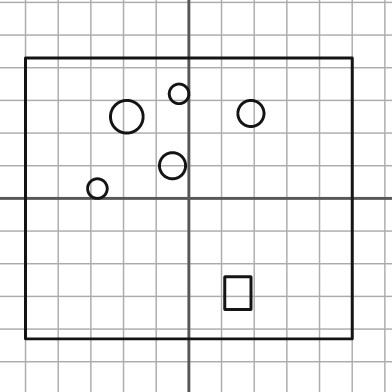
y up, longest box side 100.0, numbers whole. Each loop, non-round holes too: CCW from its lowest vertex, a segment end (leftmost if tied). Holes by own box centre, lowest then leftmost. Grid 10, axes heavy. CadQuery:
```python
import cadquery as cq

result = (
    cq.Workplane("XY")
    .moveTo(-50.0, -43.0)
    .lineTo(50.0, -43.0)
    .lineTo(50.0, 43.0)
    .lineTo(-50.0, 43.0)
    .close()
    .moveTo(11.0, -34.0)
    .lineTo(19.0, -34.0)
    .lineTo(19.0, -24.0)
    .lineTo(11.0, -24.0)
    .close()
    .moveTo(-28.0, 3.0)
    .circle(3.0)
    .moveTo(-5.0, 10.0)
    .circle(4.0)
    .moveTo(-19.0, 25.0)
    .circle(5.0)
    .moveTo(19.0, 26.0)
    .circle(4.0)
    .moveTo(-3.0, 32.0)
    .circle(3.0)
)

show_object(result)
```